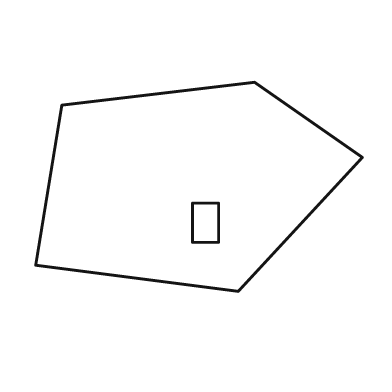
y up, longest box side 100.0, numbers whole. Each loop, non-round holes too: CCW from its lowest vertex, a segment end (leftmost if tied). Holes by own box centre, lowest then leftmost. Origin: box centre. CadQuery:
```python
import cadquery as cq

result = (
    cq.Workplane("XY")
    .moveTo(12.0, -32.0)
    .lineTo(50.0, 9.0)
    .lineTo(17.0, 32.0)
    .lineTo(-42.0, 25.0)
    .lineTo(-50.0, -24.0)
    .close()
    .moveTo(-2.0, -17.0)
    .lineTo(6.0, -17.0)
    .lineTo(6.0, -5.0)
    .lineTo(-2.0, -5.0)
    .close()
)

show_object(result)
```